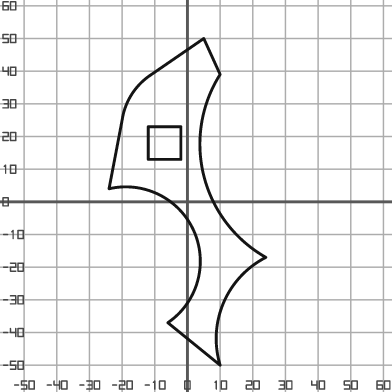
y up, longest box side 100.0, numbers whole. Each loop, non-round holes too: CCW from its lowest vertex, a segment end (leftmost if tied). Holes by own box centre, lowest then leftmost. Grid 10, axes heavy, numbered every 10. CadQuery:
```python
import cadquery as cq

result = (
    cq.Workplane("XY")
    .moveTo(10.0, -50.0)
    .threePointArc((11.0, -31.0), (24.0, -17.0))
    .threePointArc((5.0, 8.0), (10.0, 39.0))
    .lineTo(5.0, 50.0)
    .lineTo(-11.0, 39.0)
    .threePointArc((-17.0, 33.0), (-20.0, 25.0))
    .lineTo(-24.0, 4.0)
    .threePointArc((2.0, -9.0), (-6.0, -37.0))
    .close()
    .moveTo(-12.0, 13.0)
    .lineTo(-2.0, 13.0)
    .lineTo(-2.0, 23.0)
    .lineTo(-12.0, 23.0)
    .close()
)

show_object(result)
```